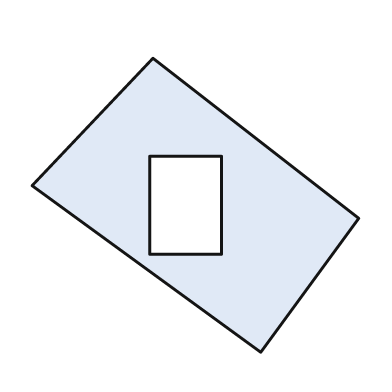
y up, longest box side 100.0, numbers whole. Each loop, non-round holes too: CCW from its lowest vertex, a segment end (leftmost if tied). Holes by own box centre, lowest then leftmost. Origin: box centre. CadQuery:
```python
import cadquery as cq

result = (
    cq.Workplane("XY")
    .moveTo(20.0, -45.0)
    .lineTo(50.0, -4.0)
    .lineTo(-13.0, 45.0)
    .lineTo(-50.0, 6.0)
    .close()
    .moveTo(-14.0, -15.0)
    .lineTo(8.0, -15.0)
    .lineTo(8.0, 15.0)
    .lineTo(-14.0, 15.0)
    .close()
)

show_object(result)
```